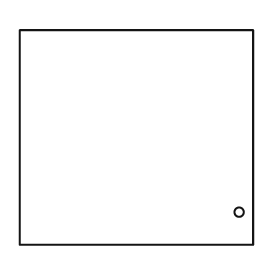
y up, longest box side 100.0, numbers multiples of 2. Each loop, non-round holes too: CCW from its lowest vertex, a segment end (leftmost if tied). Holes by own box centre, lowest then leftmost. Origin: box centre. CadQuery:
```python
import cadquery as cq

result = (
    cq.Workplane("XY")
    .moveTo(-50.0, -46.0)
    .lineTo(50.0, -46.0)
    .lineTo(50.0, 46.0)
    .lineTo(-50.0, 46.0)
    .close()
    .moveTo(44.0, -32.0)
    .circle(2.0)
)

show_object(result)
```